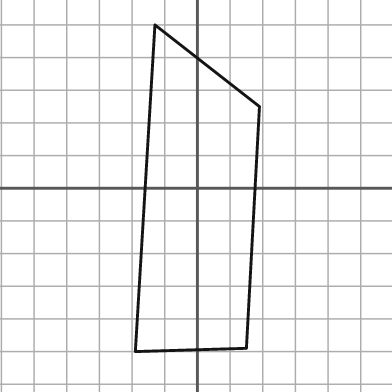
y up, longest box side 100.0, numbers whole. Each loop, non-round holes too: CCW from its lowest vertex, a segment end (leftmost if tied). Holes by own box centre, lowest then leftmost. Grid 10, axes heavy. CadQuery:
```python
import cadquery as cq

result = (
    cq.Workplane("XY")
    .moveTo(-19.0, -50.0)
    .lineTo(15.0, -49.0)
    .lineTo(19.0, 25.0)
    .lineTo(-13.0, 50.0)
    .close()
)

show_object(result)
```